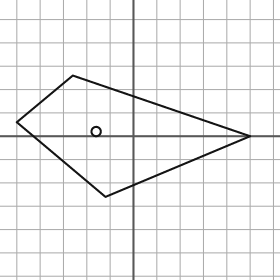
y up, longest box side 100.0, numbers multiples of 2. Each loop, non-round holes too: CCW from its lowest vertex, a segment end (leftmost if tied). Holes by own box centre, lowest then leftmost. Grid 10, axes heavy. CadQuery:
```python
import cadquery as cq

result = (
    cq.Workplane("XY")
    .moveTo(-12.0, -26.0)
    .lineTo(50.0, 0.0)
    .lineTo(-26.0, 26.0)
    .lineTo(-50.0, 6.0)
    .close()
    .moveTo(-16.0, 2.0)
    .circle(2.0)
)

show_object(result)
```